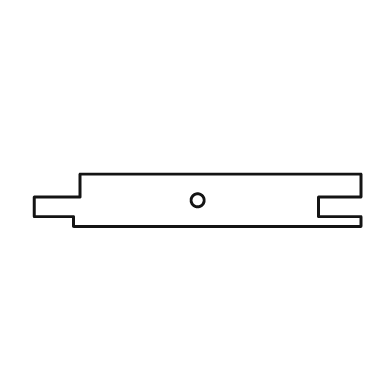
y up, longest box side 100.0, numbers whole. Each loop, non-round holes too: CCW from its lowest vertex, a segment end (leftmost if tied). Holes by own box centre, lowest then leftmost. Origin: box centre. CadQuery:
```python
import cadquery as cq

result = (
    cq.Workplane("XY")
    .moveTo(-38.0, -8.0)
    .lineTo(50.0, -8.0)
    .lineTo(50.0, -5.0)
    .lineTo(37.0, -5.0)
    .lineTo(37.0, 1.0)
    .lineTo(50.0, 1.0)
    .lineTo(50.0, 8.0)
    .lineTo(-36.0, 8.0)
    .lineTo(-36.0, 1.0)
    .lineTo(-50.0, 1.0)
    .lineTo(-50.0, -5.0)
    .lineTo(-38.0, -5.0)
    .close()
    .moveTo(0.0, 0.0)
    .circle(2.0)
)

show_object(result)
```